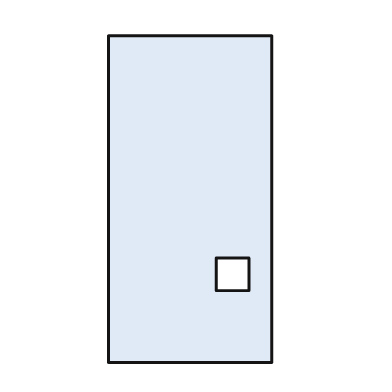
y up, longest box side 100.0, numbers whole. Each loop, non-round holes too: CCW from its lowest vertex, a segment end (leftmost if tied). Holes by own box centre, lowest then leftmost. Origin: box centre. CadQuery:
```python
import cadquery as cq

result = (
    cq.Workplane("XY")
    .moveTo(-25.0, -50.0)
    .lineTo(25.0, -50.0)
    .lineTo(25.0, 50.0)
    .lineTo(-25.0, 50.0)
    .close()
    .moveTo(8.0, -28.0)
    .lineTo(18.0, -28.0)
    .lineTo(18.0, -18.0)
    .lineTo(8.0, -18.0)
    .close()
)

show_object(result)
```